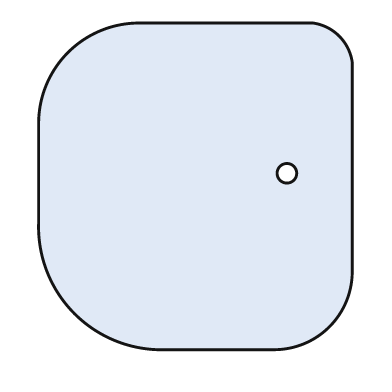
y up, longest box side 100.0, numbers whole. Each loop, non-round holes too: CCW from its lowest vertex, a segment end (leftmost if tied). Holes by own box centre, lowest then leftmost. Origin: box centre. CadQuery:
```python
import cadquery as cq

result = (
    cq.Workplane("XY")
    .moveTo(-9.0, -50.0)
    .lineTo(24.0, -50.0)
    .threePointArc((41.0, -43.0), (48.0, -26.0))
    .lineTo(48.0, 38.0)
    .threePointArc((44.0, 46.0), (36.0, 50.0))
    .lineTo(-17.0, 50.0)
    .threePointArc((-39.0, 41.0), (-48.0, 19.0))
    .lineTo(-48.0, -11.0)
    .threePointArc((-37.0, -39.0), (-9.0, -50.0))
    .close()
    .moveTo(28.0, 4.0)
    .circle(3.0)
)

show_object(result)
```